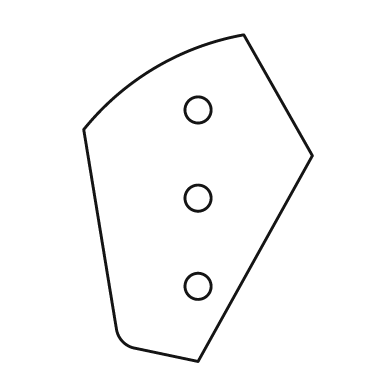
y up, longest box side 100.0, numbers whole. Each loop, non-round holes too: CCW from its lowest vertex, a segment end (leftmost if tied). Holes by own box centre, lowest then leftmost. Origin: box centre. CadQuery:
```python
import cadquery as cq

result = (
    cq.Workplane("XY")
    .moveTo(0.0, -50.0)
    .lineTo(35.0, 13.0)
    .lineTo(14.0, 50.0)
    .threePointArc((-13.0, 40.0), (-35.0, 21.0))
    .lineTo(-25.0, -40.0)
    .threePointArc((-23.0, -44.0), (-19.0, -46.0))
    .close()
    .moveTo(0.0, -27.0)
    .circle(4.0)
    .moveTo(0.0, 0.0)
    .circle(4.0)
    .moveTo(0.0, 27.0)
    .circle(4.0)
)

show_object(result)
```